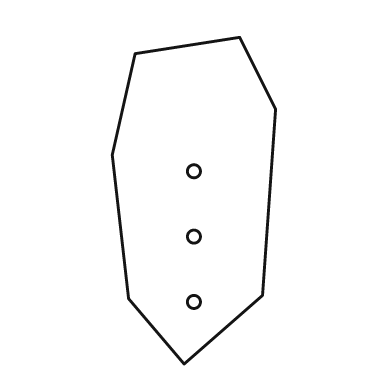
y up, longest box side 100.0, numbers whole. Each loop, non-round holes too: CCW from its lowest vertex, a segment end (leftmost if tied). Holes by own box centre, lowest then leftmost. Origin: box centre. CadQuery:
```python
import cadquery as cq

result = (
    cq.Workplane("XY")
    .moveTo(-3.0, -50.0)
    .lineTo(21.0, -29.0)
    .lineTo(25.0, 28.0)
    .lineTo(14.0, 50.0)
    .lineTo(-18.0, 45.0)
    .lineTo(-25.0, 14.0)
    .lineTo(-20.0, -30.0)
    .close()
    .moveTo(0.0, -31.0)
    .circle(2.0)
    .moveTo(0.0, -11.0)
    .circle(2.0)
    .moveTo(0.0, 9.0)
    .circle(2.0)
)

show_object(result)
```